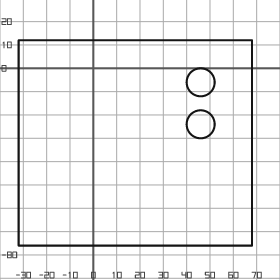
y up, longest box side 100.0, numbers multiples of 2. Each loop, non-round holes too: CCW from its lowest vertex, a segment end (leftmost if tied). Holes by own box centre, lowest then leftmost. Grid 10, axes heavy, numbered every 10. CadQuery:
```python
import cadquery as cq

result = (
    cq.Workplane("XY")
    .moveTo(-32.0, -76.0)
    .lineTo(68.0, -76.0)
    .lineTo(68.0, 12.0)
    .lineTo(-32.0, 12.0)
    .close()
    .moveTo(46.0, -24.0)
    .circle(6.0)
    .moveTo(46.0, -6.0)
    .circle(6.0)
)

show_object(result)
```